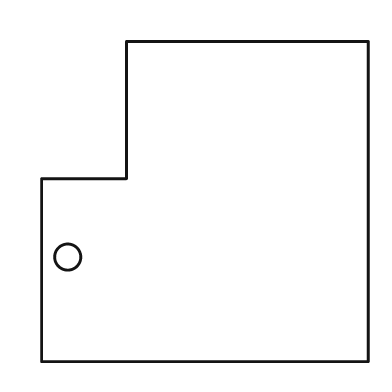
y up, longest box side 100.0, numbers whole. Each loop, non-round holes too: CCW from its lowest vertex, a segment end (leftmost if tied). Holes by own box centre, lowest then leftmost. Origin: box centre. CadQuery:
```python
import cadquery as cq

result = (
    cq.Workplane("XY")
    .moveTo(-50.0, -49.0)
    .lineTo(50.0, -49.0)
    .lineTo(50.0, 49.0)
    .lineTo(-24.0, 49.0)
    .lineTo(-24.0, 7.0)
    .lineTo(-50.0, 7.0)
    .close()
    .moveTo(-42.0, -17.0)
    .circle(4.0)
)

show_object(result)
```